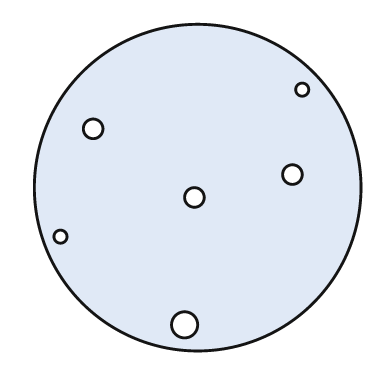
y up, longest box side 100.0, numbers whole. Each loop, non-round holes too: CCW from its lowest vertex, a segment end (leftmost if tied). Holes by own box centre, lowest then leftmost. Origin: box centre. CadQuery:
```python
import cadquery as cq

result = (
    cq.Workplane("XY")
    .moveTo(0.0, 0.0)
    .circle(50.0)
    .moveTo(-4.0, -42.0)
    .circle(4.0)
    .moveTo(-42.0, -15.0)
    .circle(2.0)
    .moveTo(-1.0, -3.0)
    .circle(3.0)
    .moveTo(29.0, 4.0)
    .circle(3.0)
    .moveTo(-32.0, 18.0)
    .circle(3.0)
    .moveTo(32.0, 30.0)
    .circle(2.0)
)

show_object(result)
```